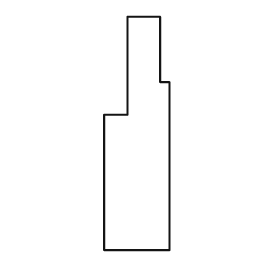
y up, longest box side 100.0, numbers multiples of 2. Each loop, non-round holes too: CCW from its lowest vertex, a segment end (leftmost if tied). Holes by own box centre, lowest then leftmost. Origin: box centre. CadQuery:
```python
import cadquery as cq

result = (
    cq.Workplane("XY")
    .moveTo(-14.0, -50.0)
    .lineTo(14.0, -50.0)
    .lineTo(14.0, 22.0)
    .lineTo(10.0, 22.0)
    .lineTo(10.0, 50.0)
    .lineTo(-4.0, 50.0)
    .lineTo(-4.0, 8.0)
    .lineTo(-14.0, 8.0)
    .close()
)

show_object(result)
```